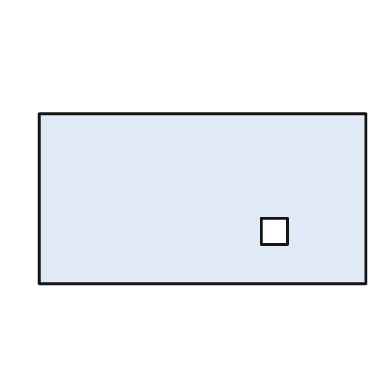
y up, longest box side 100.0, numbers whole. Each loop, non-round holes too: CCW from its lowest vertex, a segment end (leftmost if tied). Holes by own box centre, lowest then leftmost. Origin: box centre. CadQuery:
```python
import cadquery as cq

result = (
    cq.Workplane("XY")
    .moveTo(-50.0, -26.0)
    .lineTo(50.0, -26.0)
    .lineTo(50.0, 26.0)
    .lineTo(-50.0, 26.0)
    .close()
    .moveTo(18.0, -14.0)
    .lineTo(26.0, -14.0)
    .lineTo(26.0, -6.0)
    .lineTo(18.0, -6.0)
    .close()
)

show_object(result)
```